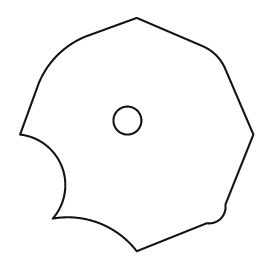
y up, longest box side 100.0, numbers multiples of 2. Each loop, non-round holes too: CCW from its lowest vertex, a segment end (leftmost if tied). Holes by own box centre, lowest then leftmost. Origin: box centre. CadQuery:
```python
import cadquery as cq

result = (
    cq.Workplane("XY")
    .moveTo(0.0, -50.0)
    .lineTo(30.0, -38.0)
    .threePointArc((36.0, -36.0), (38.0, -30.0))
    .lineTo(50.0, 0.0)
    .lineTo(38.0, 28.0)
    .threePointArc((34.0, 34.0), (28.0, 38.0))
    .lineTo(0.0, 50.0)
    .lineTo(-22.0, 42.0)
    .threePointArc((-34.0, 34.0), (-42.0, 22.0))
    .lineTo(-50.0, 0.0)
    .threePointArc((-32.0, -14.0), (-36.0, -36.0))
    .threePointArc((-16.0, -38.0), (0.0, -50.0))
    .close()
    .moveTo(-4.0, 6.0)
    .circle(6.0)
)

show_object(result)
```